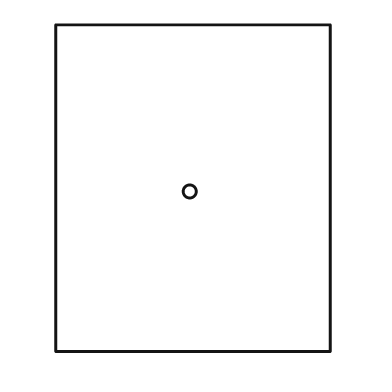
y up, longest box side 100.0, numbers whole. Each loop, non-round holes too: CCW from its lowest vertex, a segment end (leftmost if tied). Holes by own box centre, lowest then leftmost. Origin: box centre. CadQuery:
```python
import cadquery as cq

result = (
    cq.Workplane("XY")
    .moveTo(-42.0, -50.0)
    .lineTo(42.0, -50.0)
    .lineTo(42.0, 50.0)
    .lineTo(-42.0, 50.0)
    .close()
    .moveTo(-1.0, -1.0)
    .circle(2.0)
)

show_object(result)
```